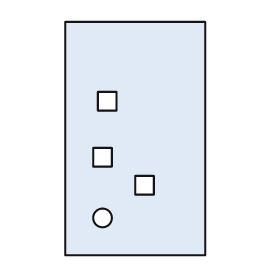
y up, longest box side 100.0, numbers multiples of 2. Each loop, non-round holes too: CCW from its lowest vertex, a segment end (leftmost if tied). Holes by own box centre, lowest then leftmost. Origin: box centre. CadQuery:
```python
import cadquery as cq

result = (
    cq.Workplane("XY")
    .moveTo(-30.0, -50.0)
    .lineTo(30.0, -50.0)
    .lineTo(30.0, 50.0)
    .lineTo(-30.0, 50.0)
    .close()
    .moveTo(-14.0, -34.0)
    .circle(4.0)
    .moveTo(0.0, -24.0)
    .lineTo(8.0, -24.0)
    .lineTo(8.0, -16.0)
    .lineTo(0.0, -16.0)
    .close()
    .moveTo(-18.0, -12.0)
    .lineTo(-10.0, -12.0)
    .lineTo(-10.0, -4.0)
    .lineTo(-18.0, -4.0)
    .close()
    .moveTo(-16.0, 12.0)
    .lineTo(-8.0, 12.0)
    .lineTo(-8.0, 20.0)
    .lineTo(-16.0, 20.0)
    .close()
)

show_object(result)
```